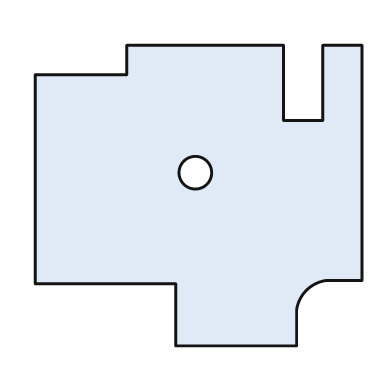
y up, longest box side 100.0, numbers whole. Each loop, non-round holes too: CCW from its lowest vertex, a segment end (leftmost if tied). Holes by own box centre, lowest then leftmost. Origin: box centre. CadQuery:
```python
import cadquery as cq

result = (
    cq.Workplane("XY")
    .moveTo(-7.0, -46.0)
    .lineTo(30.0, -46.0)
    .lineTo(30.0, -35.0)
    .threePointArc((33.0, -29.0), (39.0, -26.0))
    .lineTo(50.0, -26.0)
    .lineTo(50.0, 46.0)
    .lineTo(38.0, 46.0)
    .lineTo(38.0, 23.0)
    .lineTo(26.0, 23.0)
    .lineTo(26.0, 46.0)
    .lineTo(-22.0, 46.0)
    .lineTo(-22.0, 37.0)
    .lineTo(-50.0, 37.0)
    .lineTo(-50.0, -27.0)
    .lineTo(-7.0, -27.0)
    .close()
    .moveTo(-1.0, 7.0)
    .circle(5.0)
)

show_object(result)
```